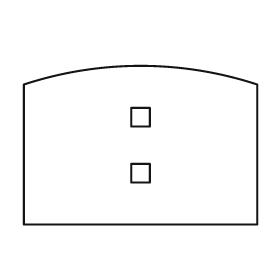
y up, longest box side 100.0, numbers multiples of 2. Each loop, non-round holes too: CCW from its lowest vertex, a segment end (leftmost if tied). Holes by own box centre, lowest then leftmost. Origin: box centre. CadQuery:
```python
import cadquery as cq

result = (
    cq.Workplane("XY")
    .moveTo(-50.0, -34.0)
    .lineTo(50.0, -34.0)
    .lineTo(50.0, 26.0)
    .threePointArc((0.0, 34.0), (-50.0, 26.0))
    .close()
    .moveTo(-4.0, -16.0)
    .lineTo(4.0, -16.0)
    .lineTo(4.0, -8.0)
    .lineTo(-4.0, -8.0)
    .close()
    .moveTo(-4.0, 8.0)
    .lineTo(4.0, 8.0)
    .lineTo(4.0, 16.0)
    .lineTo(-4.0, 16.0)
    .close()
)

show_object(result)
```